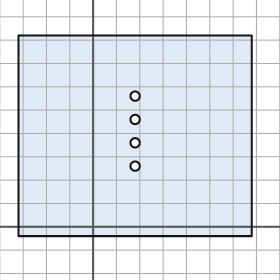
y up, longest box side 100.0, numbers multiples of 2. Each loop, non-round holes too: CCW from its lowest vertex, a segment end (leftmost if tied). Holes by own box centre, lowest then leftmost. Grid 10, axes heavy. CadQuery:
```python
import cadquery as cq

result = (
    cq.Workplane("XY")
    .moveTo(-32.0, -4.0)
    .lineTo(68.0, -4.0)
    .lineTo(68.0, 82.0)
    .lineTo(-32.0, 82.0)
    .close()
    .moveTo(18.0, 26.0)
    .circle(2.0)
    .moveTo(18.0, 36.0)
    .circle(2.0)
    .moveTo(18.0, 46.0)
    .circle(2.0)
    .moveTo(18.0, 56.0)
    .circle(2.0)
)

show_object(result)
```